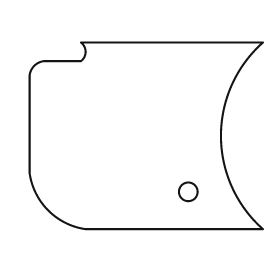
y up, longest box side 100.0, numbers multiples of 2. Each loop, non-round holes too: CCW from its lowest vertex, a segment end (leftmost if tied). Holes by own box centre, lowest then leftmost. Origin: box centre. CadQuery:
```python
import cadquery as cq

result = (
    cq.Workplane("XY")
    .moveTo(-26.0, -40.0)
    .lineTo(50.0, -40.0)
    .threePointArc((32.0, 0.0), (50.0, 40.0))
    .lineTo(-28.0, 40.0)
    .threePointArc((-26.0, 36.0), (-28.0, 32.0))
    .lineTo(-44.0, 32.0)
    .threePointArc((-48.0, 30.0), (-50.0, 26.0))
    .lineTo(-50.0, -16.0)
    .threePointArc((-42.0, -32.0), (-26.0, -40.0))
    .close()
    .moveTo(18.0, -24.0)
    .circle(4.0)
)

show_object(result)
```